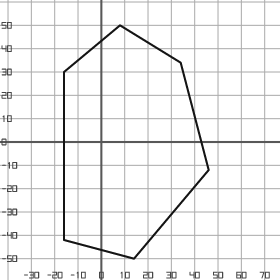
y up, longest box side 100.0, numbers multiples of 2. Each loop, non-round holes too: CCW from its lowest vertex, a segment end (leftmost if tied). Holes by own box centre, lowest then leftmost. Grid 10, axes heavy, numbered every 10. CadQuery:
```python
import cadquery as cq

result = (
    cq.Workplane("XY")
    .moveTo(14.0, -50.0)
    .lineTo(46.0, -12.0)
    .lineTo(34.0, 34.0)
    .lineTo(8.0, 50.0)
    .lineTo(-16.0, 30.0)
    .lineTo(-16.0, -42.0)
    .close()
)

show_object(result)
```